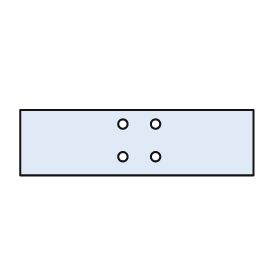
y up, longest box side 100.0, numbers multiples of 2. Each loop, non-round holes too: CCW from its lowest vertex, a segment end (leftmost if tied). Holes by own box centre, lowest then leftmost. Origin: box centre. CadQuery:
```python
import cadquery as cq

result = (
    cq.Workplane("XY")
    .moveTo(-50.0, -14.0)
    .lineTo(50.0, -14.0)
    .lineTo(50.0, 14.0)
    .lineTo(-50.0, 14.0)
    .close()
    .moveTo(-6.0, -6.0)
    .circle(2.0)
    .moveTo(8.0, -6.0)
    .circle(2.0)
    .moveTo(-6.0, 8.0)
    .circle(2.0)
    .moveTo(8.0, 8.0)
    .circle(2.0)
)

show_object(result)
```